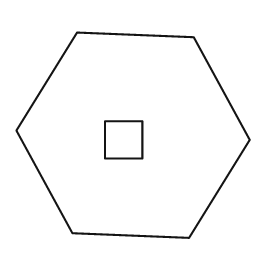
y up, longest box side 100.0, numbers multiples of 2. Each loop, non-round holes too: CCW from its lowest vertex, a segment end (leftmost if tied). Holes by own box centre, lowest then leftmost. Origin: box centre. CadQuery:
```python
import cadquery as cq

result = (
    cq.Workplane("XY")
    .moveTo(24.0, -44.0)
    .lineTo(50.0, -2.0)
    .lineTo(26.0, 42.0)
    .lineTo(-24.0, 44.0)
    .lineTo(-50.0, 2.0)
    .lineTo(-26.0, -42.0)
    .close()
    .moveTo(-12.0, -10.0)
    .lineTo(4.0, -10.0)
    .lineTo(4.0, 6.0)
    .lineTo(-12.0, 6.0)
    .close()
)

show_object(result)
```